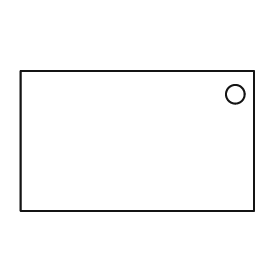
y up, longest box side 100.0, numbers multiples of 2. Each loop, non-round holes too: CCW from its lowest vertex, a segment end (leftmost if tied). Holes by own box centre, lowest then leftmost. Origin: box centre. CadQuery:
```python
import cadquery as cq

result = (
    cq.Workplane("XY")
    .moveTo(-50.0, -30.0)
    .lineTo(50.0, -30.0)
    .lineTo(50.0, 30.0)
    .lineTo(-50.0, 30.0)
    .close()
    .moveTo(42.0, 20.0)
    .circle(4.0)
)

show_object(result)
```